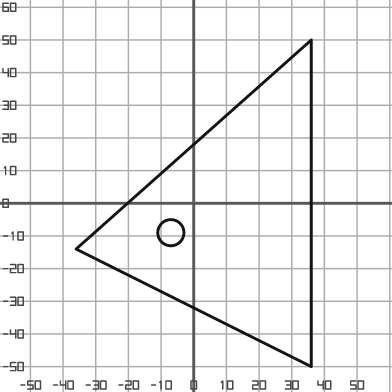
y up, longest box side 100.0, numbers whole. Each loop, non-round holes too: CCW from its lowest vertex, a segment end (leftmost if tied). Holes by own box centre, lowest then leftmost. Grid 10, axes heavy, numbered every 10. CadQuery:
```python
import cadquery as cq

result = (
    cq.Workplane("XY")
    .moveTo(36.0, -50.0)
    .lineTo(36.0, 50.0)
    .lineTo(-36.0, -14.0)
    .close()
    .moveTo(-7.0, -9.0)
    .circle(4.0)
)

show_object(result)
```